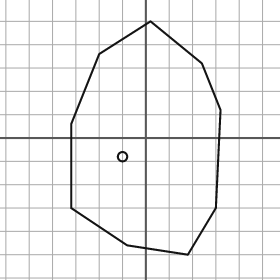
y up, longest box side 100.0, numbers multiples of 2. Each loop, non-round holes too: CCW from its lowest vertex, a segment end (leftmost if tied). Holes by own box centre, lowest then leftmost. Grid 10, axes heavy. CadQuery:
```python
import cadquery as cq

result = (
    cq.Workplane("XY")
    .moveTo(18.0, -50.0)
    .lineTo(30.0, -30.0)
    .lineTo(32.0, 12.0)
    .lineTo(24.0, 32.0)
    .lineTo(2.0, 50.0)
    .lineTo(-20.0, 36.0)
    .lineTo(-32.0, 6.0)
    .lineTo(-32.0, -30.0)
    .lineTo(-8.0, -46.0)
    .close()
    .moveTo(-10.0, -8.0)
    .circle(2.0)
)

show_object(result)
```